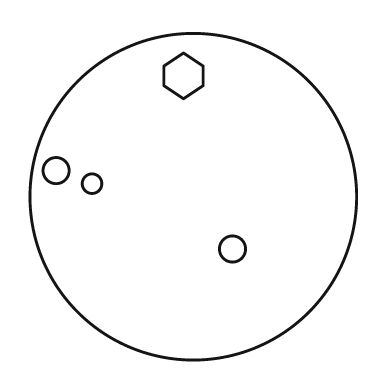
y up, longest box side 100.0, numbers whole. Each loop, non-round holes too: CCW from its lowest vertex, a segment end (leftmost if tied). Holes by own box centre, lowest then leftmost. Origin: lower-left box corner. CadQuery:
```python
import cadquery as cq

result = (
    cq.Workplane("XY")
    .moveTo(50.0, 50.0)
    .circle(50.0)
    .moveTo(62.0, 34.0)
    .circle(4.0)
    .moveTo(19.0, 54.0)
    .circle(3.0)
    .moveTo(8.0, 58.0)
    .circle(4.0)
    .moveTo(47.0, 80.0)
    .lineTo(53.0, 84.0)
    .lineTo(53.0, 90.0)
    .lineTo(47.0, 94.0)
    .lineTo(41.0, 90.0)
    .lineTo(41.0, 84.0)
    .close()
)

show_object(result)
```